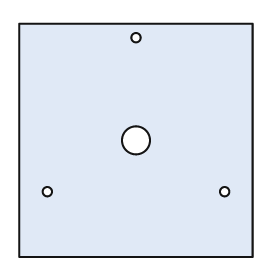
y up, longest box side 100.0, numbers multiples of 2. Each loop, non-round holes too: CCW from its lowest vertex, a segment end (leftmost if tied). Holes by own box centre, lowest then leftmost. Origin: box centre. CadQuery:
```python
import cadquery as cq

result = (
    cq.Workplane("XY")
    .moveTo(-50.0, -50.0)
    .lineTo(50.0, -50.0)
    .lineTo(50.0, 50.0)
    .lineTo(-50.0, 50.0)
    .close()
    .moveTo(-38.0, -22.0)
    .circle(2.0)
    .moveTo(38.0, -22.0)
    .circle(2.0)
    .moveTo(0.0, 0.0)
    .circle(6.0)
    .moveTo(0.0, 44.0)
    .circle(2.0)
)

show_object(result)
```